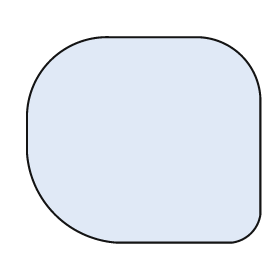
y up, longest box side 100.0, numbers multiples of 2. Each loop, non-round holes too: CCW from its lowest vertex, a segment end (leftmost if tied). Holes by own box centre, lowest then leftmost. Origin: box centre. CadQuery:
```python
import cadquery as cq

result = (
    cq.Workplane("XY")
    .moveTo(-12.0, -44.0)
    .lineTo(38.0, -44.0)
    .threePointArc((46.0, -40.0), (50.0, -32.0))
    .lineTo(50.0, 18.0)
    .threePointArc((42.0, 36.0), (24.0, 44.0))
    .lineTo(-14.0, 44.0)
    .threePointArc((-40.0, 34.0), (-50.0, 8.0))
    .lineTo(-50.0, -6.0)
    .threePointArc((-38.0, -32.0), (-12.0, -44.0))
    .close()
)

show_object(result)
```